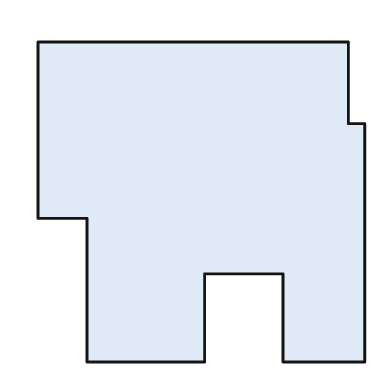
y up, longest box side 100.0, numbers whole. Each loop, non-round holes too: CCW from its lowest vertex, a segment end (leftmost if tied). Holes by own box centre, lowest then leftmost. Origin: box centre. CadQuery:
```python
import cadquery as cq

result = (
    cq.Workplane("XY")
    .moveTo(-35.0, -49.0)
    .lineTo(1.0, -49.0)
    .lineTo(1.0, -22.0)
    .lineTo(25.0, -22.0)
    .lineTo(25.0, -49.0)
    .lineTo(50.0, -49.0)
    .lineTo(50.0, 24.0)
    .lineTo(45.0, 24.0)
    .lineTo(45.0, 49.0)
    .lineTo(-50.0, 49.0)
    .lineTo(-50.0, -5.0)
    .lineTo(-35.0, -5.0)
    .close()
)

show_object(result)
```